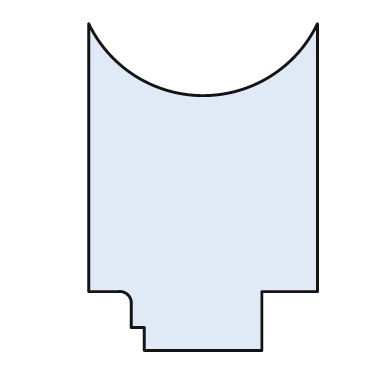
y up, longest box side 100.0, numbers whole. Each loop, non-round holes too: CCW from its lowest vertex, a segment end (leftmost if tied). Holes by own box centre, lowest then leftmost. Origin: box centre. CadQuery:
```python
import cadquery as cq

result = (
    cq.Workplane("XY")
    .moveTo(-18.0, -50.0)
    .lineTo(18.0, -50.0)
    .lineTo(18.0, -32.0)
    .lineTo(35.0, -32.0)
    .lineTo(35.0, 50.0)
    .threePointArc((0.0, 28.0), (-35.0, 50.0))
    .lineTo(-35.0, -32.0)
    .lineTo(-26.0, -32.0)
    .threePointArc((-23.0, -33.0), (-22.0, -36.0))
    .lineTo(-22.0, -43.0)
    .lineTo(-18.0, -43.0)
    .close()
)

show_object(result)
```